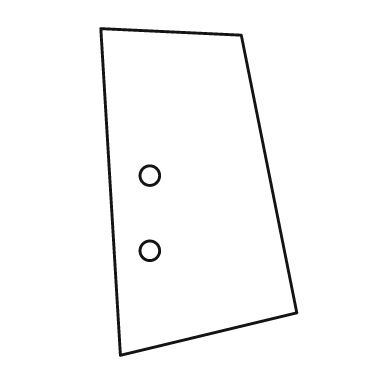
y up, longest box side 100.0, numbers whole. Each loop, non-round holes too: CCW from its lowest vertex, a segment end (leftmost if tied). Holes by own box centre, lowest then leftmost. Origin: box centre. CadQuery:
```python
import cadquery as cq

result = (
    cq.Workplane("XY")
    .moveTo(-24.0, -50.0)
    .lineTo(30.0, -37.0)
    .lineTo(13.0, 48.0)
    .lineTo(-30.0, 50.0)
    .close()
    .moveTo(-15.0, -18.0)
    .circle(3.0)
    .moveTo(-15.0, 5.0)
    .circle(3.0)
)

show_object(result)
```